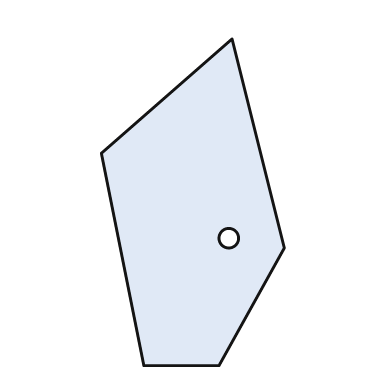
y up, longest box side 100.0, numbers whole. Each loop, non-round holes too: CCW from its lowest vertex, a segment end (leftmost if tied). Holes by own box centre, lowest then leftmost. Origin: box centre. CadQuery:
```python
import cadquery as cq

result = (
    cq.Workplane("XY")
    .moveTo(-15.0, -50.0)
    .lineTo(8.0, -50.0)
    .lineTo(28.0, -14.0)
    .lineTo(12.0, 50.0)
    .lineTo(-28.0, 15.0)
    .close()
    .moveTo(11.0, -11.0)
    .circle(3.0)
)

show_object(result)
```